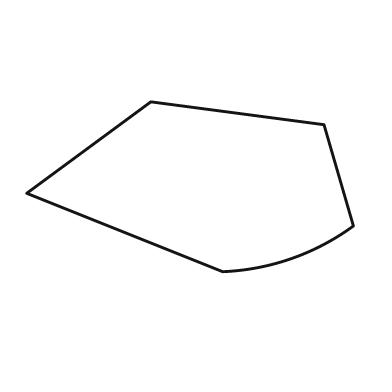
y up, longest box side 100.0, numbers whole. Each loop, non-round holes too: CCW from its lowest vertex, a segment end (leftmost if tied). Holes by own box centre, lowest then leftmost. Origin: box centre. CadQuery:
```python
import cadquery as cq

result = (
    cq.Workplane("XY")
    .moveTo(10.0, -26.0)
    .threePointArc((31.0, -22.0), (50.0, -12.0))
    .lineTo(41.0, 19.0)
    .lineTo(-12.0, 26.0)
    .lineTo(-50.0, -2.0)
    .close()
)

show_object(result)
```